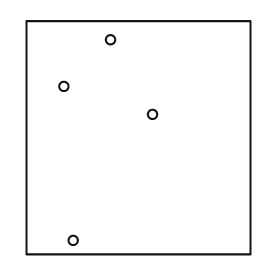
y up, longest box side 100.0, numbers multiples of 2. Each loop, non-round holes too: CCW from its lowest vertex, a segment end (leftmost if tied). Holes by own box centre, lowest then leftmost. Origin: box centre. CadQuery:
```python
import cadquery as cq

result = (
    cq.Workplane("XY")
    .moveTo(-48.0, -50.0)
    .lineTo(48.0, -50.0)
    .lineTo(48.0, 50.0)
    .lineTo(-48.0, 50.0)
    .close()
    .moveTo(-28.0, -44.0)
    .circle(2.0)
    .moveTo(6.0, 10.0)
    .circle(2.0)
    .moveTo(-32.0, 22.0)
    .circle(2.0)
    .moveTo(-12.0, 42.0)
    .circle(2.0)
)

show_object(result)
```